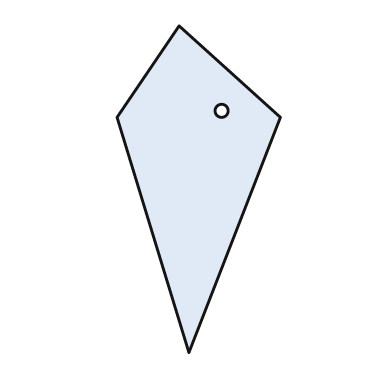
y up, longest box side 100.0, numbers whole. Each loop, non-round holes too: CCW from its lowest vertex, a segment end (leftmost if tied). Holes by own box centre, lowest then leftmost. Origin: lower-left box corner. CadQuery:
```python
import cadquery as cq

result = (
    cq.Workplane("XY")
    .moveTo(22.0, 0.0)
    .lineTo(50.0, 72.0)
    .lineTo(19.0, 100.0)
    .lineTo(0.0, 72.0)
    .close()
    .moveTo(32.0, 74.0)
    .circle(2.0)
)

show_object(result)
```